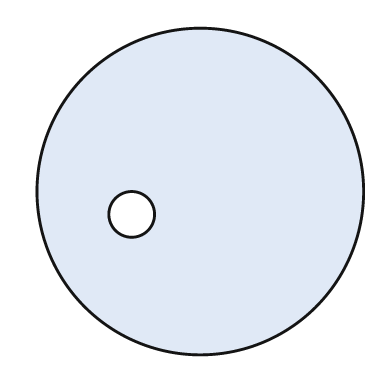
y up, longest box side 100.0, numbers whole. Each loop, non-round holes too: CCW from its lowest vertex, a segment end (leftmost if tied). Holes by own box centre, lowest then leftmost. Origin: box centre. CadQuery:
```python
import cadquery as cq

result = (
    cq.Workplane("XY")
    .moveTo(0.0, 0.0)
    .circle(50.0)
    .moveTo(-21.0, -7.0)
    .circle(7.0)
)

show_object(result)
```